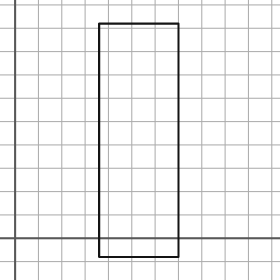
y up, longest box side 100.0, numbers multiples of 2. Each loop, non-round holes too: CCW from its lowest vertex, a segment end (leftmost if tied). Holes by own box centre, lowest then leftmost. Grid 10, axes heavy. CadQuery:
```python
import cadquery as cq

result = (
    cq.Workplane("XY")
    .moveTo(36.0, -8.0)
    .lineTo(70.0, -8.0)
    .lineTo(70.0, 92.0)
    .lineTo(36.0, 92.0)
    .close()
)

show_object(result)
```